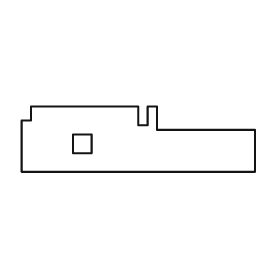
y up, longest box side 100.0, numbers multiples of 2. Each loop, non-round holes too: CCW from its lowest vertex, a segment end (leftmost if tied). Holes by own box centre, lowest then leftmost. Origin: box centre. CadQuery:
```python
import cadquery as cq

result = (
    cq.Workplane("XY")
    .moveTo(-50.0, -14.0)
    .lineTo(50.0, -14.0)
    .lineTo(50.0, 4.0)
    .lineTo(8.0, 4.0)
    .lineTo(8.0, 14.0)
    .lineTo(4.0, 14.0)
    .lineTo(4.0, 6.0)
    .lineTo(0.0, 6.0)
    .lineTo(0.0, 14.0)
    .lineTo(-46.0, 14.0)
    .lineTo(-46.0, 8.0)
    .lineTo(-50.0, 8.0)
    .close()
    .moveTo(-28.0, -6.0)
    .lineTo(-20.0, -6.0)
    .lineTo(-20.0, 2.0)
    .lineTo(-28.0, 2.0)
    .close()
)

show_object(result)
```